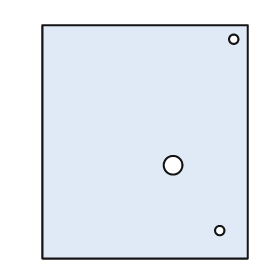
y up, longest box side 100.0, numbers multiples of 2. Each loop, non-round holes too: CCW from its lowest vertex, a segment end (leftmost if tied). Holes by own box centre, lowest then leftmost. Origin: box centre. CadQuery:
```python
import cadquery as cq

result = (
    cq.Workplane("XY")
    .moveTo(-44.0, -50.0)
    .lineTo(44.0, -50.0)
    .lineTo(44.0, 50.0)
    .lineTo(-44.0, 50.0)
    .close()
    .moveTo(32.0, -38.0)
    .circle(2.0)
    .moveTo(12.0, -10.0)
    .circle(4.0)
    .moveTo(38.0, 44.0)
    .circle(2.0)
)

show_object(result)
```